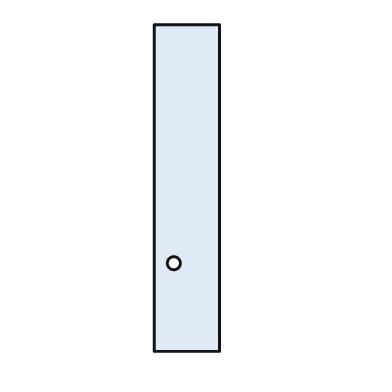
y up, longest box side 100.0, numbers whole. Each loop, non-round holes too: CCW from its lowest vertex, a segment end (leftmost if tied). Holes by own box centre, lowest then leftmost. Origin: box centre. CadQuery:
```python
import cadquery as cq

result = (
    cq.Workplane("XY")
    .moveTo(-10.0, -50.0)
    .lineTo(10.0, -50.0)
    .lineTo(10.0, 50.0)
    .lineTo(-10.0, 50.0)
    .close()
    .moveTo(-4.0, -23.0)
    .circle(2.0)
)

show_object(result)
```